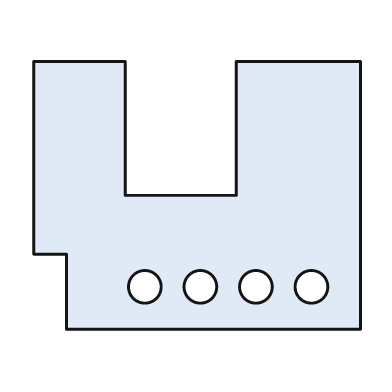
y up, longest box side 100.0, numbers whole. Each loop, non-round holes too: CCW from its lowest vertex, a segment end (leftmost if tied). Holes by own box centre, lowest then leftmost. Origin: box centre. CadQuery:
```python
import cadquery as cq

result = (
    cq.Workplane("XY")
    .moveTo(-40.0, -41.0)
    .lineTo(50.0, -41.0)
    .lineTo(50.0, 41.0)
    .lineTo(12.0, 41.0)
    .lineTo(12.0, 0.0)
    .lineTo(-22.0, 0.0)
    .lineTo(-22.0, 41.0)
    .lineTo(-50.0, 41.0)
    .lineTo(-50.0, -18.0)
    .lineTo(-40.0, -18.0)
    .close()
    .moveTo(-16.0, -28.0)
    .circle(5.0)
    .moveTo(1.0, -28.0)
    .circle(5.0)
    .moveTo(18.0, -28.0)
    .circle(5.0)
    .moveTo(35.0, -28.0)
    .circle(5.0)
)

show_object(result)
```